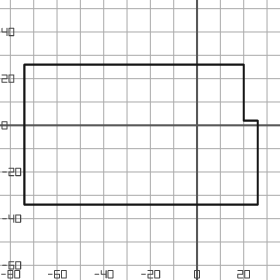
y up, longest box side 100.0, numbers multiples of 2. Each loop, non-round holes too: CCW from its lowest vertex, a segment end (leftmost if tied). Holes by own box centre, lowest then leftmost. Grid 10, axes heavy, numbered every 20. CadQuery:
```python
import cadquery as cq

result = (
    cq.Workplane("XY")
    .moveTo(-74.0, -34.0)
    .lineTo(26.0, -34.0)
    .lineTo(26.0, 2.0)
    .lineTo(20.0, 2.0)
    .lineTo(20.0, 26.0)
    .lineTo(-74.0, 26.0)
    .close()
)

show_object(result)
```